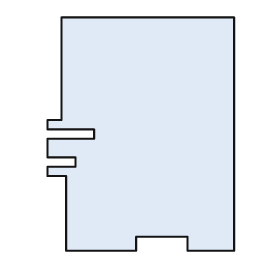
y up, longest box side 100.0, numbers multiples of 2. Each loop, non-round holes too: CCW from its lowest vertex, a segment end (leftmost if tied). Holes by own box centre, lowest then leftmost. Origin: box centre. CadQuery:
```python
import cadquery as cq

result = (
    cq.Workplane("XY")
    .moveTo(-32.0, -50.0)
    .lineTo(-2.0, -50.0)
    .lineTo(-2.0, -44.0)
    .lineTo(20.0, -44.0)
    .lineTo(20.0, -50.0)
    .lineTo(40.0, -50.0)
    .lineTo(40.0, 50.0)
    .lineTo(-34.0, 50.0)
    .lineTo(-34.0, 6.0)
    .lineTo(-40.0, 6.0)
    .lineTo(-40.0, 2.0)
    .lineTo(-20.0, 2.0)
    .lineTo(-20.0, -2.0)
    .lineTo(-40.0, -2.0)
    .lineTo(-40.0, -10.0)
    .lineTo(-28.0, -10.0)
    .lineTo(-28.0, -14.0)
    .lineTo(-40.0, -14.0)
    .lineTo(-40.0, -18.0)
    .lineTo(-32.0, -18.0)
    .close()
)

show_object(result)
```